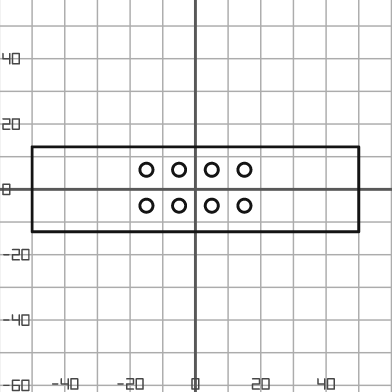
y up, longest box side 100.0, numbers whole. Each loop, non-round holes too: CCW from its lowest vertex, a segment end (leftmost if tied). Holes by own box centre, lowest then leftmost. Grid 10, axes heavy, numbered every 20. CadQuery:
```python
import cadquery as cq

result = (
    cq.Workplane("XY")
    .moveTo(-50.0, -13.0)
    .lineTo(50.0, -13.0)
    .lineTo(50.0, 13.0)
    .lineTo(-50.0, 13.0)
    .close()
    .moveTo(-15.0, -5.0)
    .circle(2.0)
    .moveTo(-5.0, -5.0)
    .circle(2.0)
    .moveTo(5.0, -5.0)
    .circle(2.0)
    .moveTo(15.0, -5.0)
    .circle(2.0)
    .moveTo(-15.0, 6.0)
    .circle(2.0)
    .moveTo(-5.0, 6.0)
    .circle(2.0)
    .moveTo(5.0, 6.0)
    .circle(2.0)
    .moveTo(15.0, 6.0)
    .circle(2.0)
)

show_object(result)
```